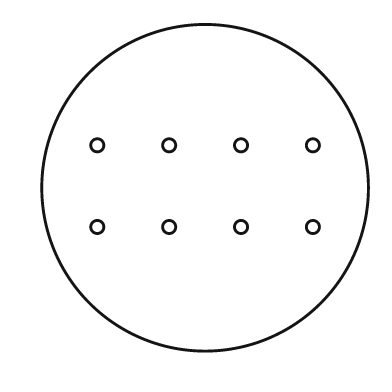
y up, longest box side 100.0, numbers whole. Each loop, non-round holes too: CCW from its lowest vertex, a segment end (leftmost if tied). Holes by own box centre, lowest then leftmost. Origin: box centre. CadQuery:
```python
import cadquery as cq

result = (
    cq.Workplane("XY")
    .moveTo(0.0, 0.0)
    .circle(50.0)
    .moveTo(-33.0, -12.0)
    .circle(2.0)
    .moveTo(-11.0, -12.0)
    .circle(2.0)
    .moveTo(11.0, -12.0)
    .circle(2.0)
    .moveTo(33.0, -12.0)
    .circle(2.0)
    .moveTo(-33.0, 13.0)
    .circle(2.0)
    .moveTo(-11.0, 13.0)
    .circle(2.0)
    .moveTo(11.0, 13.0)
    .circle(2.0)
    .moveTo(33.0, 13.0)
    .circle(2.0)
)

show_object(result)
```